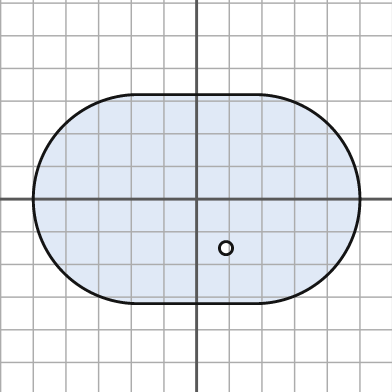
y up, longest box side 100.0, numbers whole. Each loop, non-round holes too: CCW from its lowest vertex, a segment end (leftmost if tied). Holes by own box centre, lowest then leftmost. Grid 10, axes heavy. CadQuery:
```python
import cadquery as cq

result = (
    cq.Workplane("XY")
    .moveTo(-18.0, -32.0)
    .lineTo(18.0, -32.0)
    .threePointArc((50.0, 0.0), (18.0, 32.0))
    .lineTo(-18.0, 32.0)
    .threePointArc((-50.0, 0.0), (-18.0, -32.0))
    .close()
    .moveTo(9.0, -15.0)
    .circle(2.0)
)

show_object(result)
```